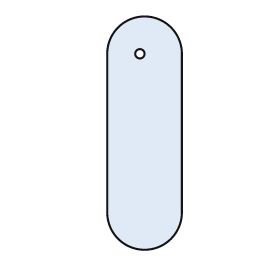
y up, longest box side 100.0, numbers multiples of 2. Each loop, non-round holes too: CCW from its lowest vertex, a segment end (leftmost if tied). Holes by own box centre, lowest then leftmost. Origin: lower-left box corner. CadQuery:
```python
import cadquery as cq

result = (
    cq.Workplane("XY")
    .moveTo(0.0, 16.0)
    .threePointArc((16.0, 0.0), (32.0, 16.0))
    .lineTo(32.0, 84.0)
    .threePointArc((16.0, 100.0), (0.0, 84.0))
    .close()
    .moveTo(14.0, 84.0)
    .circle(2.0)
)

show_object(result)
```